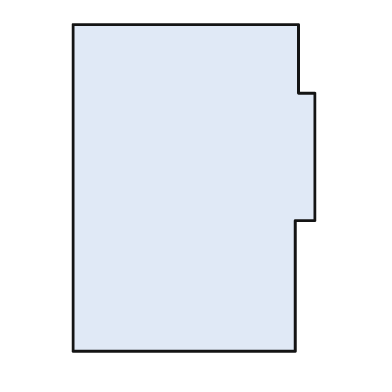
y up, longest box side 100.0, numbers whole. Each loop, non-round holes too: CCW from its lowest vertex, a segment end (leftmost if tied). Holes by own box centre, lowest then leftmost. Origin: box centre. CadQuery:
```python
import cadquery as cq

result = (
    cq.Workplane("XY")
    .moveTo(-37.0, -50.0)
    .lineTo(31.0, -50.0)
    .lineTo(31.0, -10.0)
    .lineTo(37.0, -10.0)
    .lineTo(37.0, 29.0)
    .lineTo(32.0, 29.0)
    .lineTo(32.0, 50.0)
    .lineTo(-37.0, 50.0)
    .close()
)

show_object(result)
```